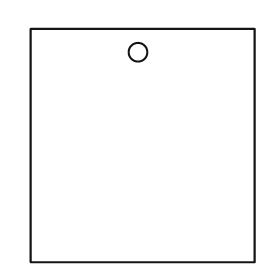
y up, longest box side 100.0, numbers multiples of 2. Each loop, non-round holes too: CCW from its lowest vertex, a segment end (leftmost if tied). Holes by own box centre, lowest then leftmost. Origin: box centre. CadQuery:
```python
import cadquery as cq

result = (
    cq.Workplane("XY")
    .moveTo(-48.0, -50.0)
    .lineTo(48.0, -50.0)
    .lineTo(48.0, 50.0)
    .lineTo(-48.0, 50.0)
    .close()
    .moveTo(-2.0, 40.0)
    .circle(4.0)
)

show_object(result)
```